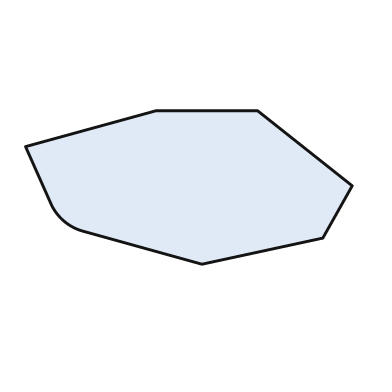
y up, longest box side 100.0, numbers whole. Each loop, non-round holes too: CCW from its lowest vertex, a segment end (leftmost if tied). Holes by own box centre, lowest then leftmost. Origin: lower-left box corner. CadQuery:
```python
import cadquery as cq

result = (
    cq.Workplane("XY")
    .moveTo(54.0, 0.0)
    .lineTo(91.0, 8.0)
    .lineTo(100.0, 24.0)
    .lineTo(71.0, 47.0)
    .lineTo(40.0, 47.0)
    .lineTo(0.0, 36.0)
    .lineTo(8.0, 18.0)
    .threePointArc((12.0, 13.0), (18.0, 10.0))
    .close()
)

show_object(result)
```